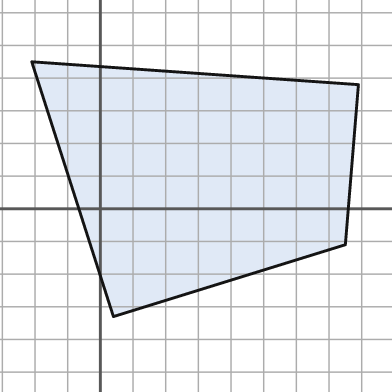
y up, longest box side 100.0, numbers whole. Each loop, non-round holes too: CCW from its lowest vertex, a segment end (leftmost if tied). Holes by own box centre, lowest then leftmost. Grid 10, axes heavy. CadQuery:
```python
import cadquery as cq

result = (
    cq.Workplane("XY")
    .moveTo(4.0, -33.0)
    .lineTo(75.0, -11.0)
    .lineTo(79.0, 38.0)
    .lineTo(-21.0, 45.0)
    .close()
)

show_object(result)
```